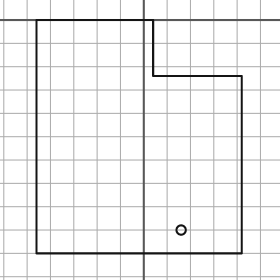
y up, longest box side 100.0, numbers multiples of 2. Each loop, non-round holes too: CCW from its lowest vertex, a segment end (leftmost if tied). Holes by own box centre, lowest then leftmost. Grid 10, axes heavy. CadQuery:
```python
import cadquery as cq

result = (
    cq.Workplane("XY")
    .moveTo(-46.0, -100.0)
    .lineTo(42.0, -100.0)
    .lineTo(42.0, -24.0)
    .lineTo(4.0, -24.0)
    .lineTo(4.0, 0.0)
    .lineTo(-46.0, 0.0)
    .close()
    .moveTo(16.0, -90.0)
    .circle(2.0)
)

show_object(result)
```